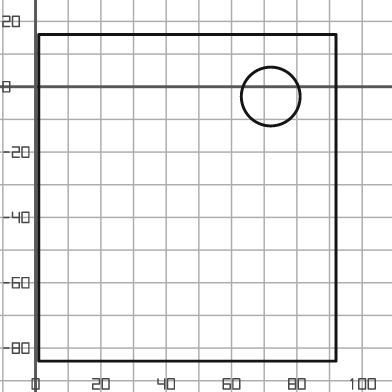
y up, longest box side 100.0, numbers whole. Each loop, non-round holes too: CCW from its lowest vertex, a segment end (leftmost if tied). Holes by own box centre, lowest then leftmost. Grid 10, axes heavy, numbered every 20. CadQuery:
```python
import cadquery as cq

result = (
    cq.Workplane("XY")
    .moveTo(1.0, -84.0)
    .lineTo(92.0, -84.0)
    .lineTo(92.0, 16.0)
    .lineTo(1.0, 16.0)
    .close()
    .moveTo(72.0, -3.0)
    .circle(9.0)
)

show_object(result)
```